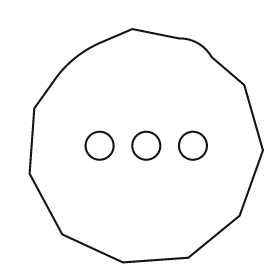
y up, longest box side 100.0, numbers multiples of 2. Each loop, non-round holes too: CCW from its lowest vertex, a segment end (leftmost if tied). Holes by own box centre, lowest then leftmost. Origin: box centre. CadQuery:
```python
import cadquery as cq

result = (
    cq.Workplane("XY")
    .moveTo(-10.0, -50.0)
    .lineTo(18.0, -48.0)
    .lineTo(40.0, -30.0)
    .lineTo(50.0, -2.0)
    .lineTo(42.0, 26.0)
    .lineTo(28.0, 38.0)
    .threePointArc((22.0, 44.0), (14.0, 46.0))
    .lineTo(-6.0, 50.0)
    .lineTo(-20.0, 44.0)
    .threePointArc((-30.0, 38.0), (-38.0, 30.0))
    .lineTo(-48.0, 16.0)
    .lineTo(-50.0, -12.0)
    .lineTo(-36.0, -38.0)
    .close()
    .moveTo(-20.0, 0.0)
    .circle(6.0)
    .moveTo(0.0, 0.0)
    .circle(6.0)
    .moveTo(20.0, 0.0)
    .circle(6.0)
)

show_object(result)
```